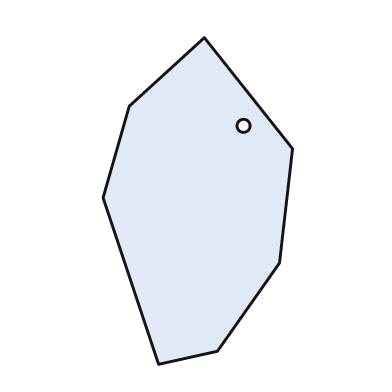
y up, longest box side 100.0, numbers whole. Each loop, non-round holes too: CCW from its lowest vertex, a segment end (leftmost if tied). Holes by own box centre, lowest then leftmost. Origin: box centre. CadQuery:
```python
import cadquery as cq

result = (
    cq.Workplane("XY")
    .moveTo(-12.0, -50.0)
    .lineTo(6.0, -46.0)
    .lineTo(25.0, -19.0)
    .lineTo(29.0, 16.0)
    .lineTo(2.0, 50.0)
    .lineTo(-21.0, 29.0)
    .lineTo(-29.0, 1.0)
    .close()
    .moveTo(14.0, 23.0)
    .circle(2.0)
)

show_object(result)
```